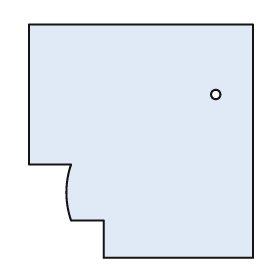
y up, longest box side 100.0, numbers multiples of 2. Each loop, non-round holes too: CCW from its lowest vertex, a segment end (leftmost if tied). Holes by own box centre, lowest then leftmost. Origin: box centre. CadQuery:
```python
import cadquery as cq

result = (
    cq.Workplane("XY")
    .moveTo(-16.0, -50.0)
    .lineTo(48.0, -50.0)
    .lineTo(48.0, 50.0)
    .lineTo(-48.0, 50.0)
    .lineTo(-48.0, -10.0)
    .lineTo(-30.0, -10.0)
    .threePointArc((-32.0, -22.0), (-30.0, -34.0))
    .lineTo(-16.0, -34.0)
    .close()
    .moveTo(32.0, 20.0)
    .circle(2.0)
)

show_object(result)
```